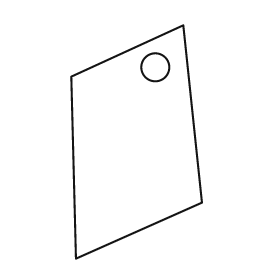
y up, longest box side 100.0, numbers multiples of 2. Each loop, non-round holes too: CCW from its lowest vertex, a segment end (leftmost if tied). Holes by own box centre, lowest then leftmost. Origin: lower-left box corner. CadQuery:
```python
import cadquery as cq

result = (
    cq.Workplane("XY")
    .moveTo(2.0, 0.0)
    .lineTo(56.0, 24.0)
    .lineTo(48.0, 100.0)
    .lineTo(0.0, 78.0)
    .close()
    .moveTo(36.0, 82.0)
    .circle(6.0)
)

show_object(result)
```